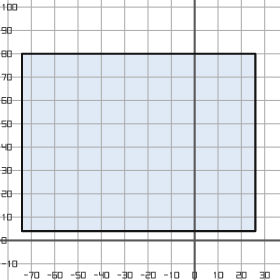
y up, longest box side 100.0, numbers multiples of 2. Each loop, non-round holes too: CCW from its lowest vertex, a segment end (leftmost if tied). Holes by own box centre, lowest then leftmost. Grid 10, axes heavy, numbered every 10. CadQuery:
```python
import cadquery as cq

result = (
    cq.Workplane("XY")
    .moveTo(-74.0, 4.0)
    .lineTo(26.0, 4.0)
    .lineTo(26.0, 80.0)
    .lineTo(-74.0, 80.0)
    .close()
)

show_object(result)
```